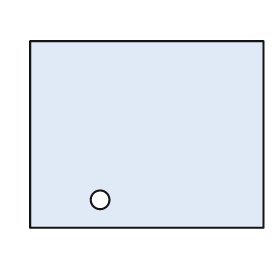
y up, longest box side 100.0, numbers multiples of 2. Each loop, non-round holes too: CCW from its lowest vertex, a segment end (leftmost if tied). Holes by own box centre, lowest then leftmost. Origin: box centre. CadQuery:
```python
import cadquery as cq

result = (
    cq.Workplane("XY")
    .moveTo(-50.0, -40.0)
    .lineTo(50.0, -40.0)
    .lineTo(50.0, 40.0)
    .lineTo(-50.0, 40.0)
    .close()
    .moveTo(-20.0, -28.0)
    .circle(4.0)
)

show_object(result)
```